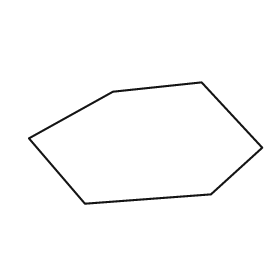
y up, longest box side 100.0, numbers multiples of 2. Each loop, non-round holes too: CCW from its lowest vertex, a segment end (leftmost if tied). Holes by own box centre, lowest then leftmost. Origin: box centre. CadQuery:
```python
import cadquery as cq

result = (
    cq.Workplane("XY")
    .moveTo(-26.0, -26.0)
    .lineTo(28.0, -22.0)
    .lineTo(50.0, -2.0)
    .lineTo(24.0, 26.0)
    .lineTo(-14.0, 22.0)
    .lineTo(-50.0, 2.0)
    .close()
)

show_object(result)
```